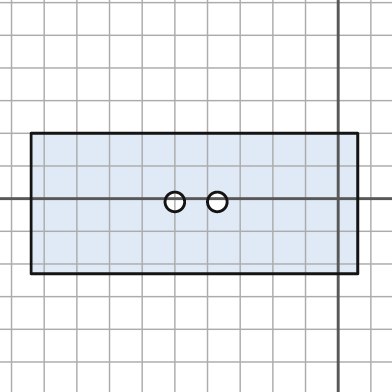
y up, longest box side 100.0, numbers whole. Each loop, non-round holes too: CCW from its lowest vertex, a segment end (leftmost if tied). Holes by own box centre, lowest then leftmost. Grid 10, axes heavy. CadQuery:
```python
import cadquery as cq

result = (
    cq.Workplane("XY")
    .moveTo(-94.0, -23.0)
    .lineTo(6.0, -23.0)
    .lineTo(6.0, 20.0)
    .lineTo(-94.0, 20.0)
    .close()
    .moveTo(-50.0, -1.0)
    .circle(3.0)
    .moveTo(-37.0, -1.0)
    .circle(3.0)
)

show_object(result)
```